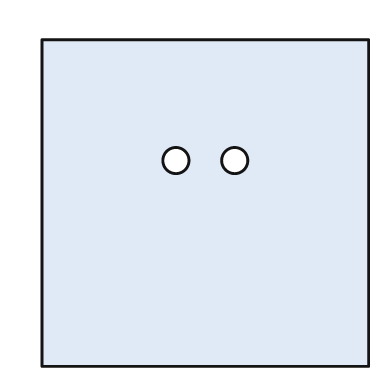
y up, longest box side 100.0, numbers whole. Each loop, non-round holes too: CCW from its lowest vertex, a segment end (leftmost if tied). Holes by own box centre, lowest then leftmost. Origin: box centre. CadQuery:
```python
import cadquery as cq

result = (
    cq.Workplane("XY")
    .moveTo(-50.0, -50.0)
    .lineTo(50.0, -50.0)
    .lineTo(50.0, 50.0)
    .lineTo(-50.0, 50.0)
    .close()
    .moveTo(-9.0, 13.0)
    .circle(4.0)
    .moveTo(9.0, 13.0)
    .circle(4.0)
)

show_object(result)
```